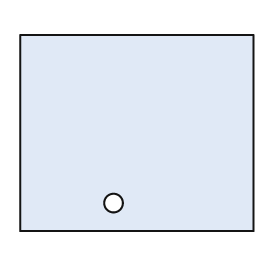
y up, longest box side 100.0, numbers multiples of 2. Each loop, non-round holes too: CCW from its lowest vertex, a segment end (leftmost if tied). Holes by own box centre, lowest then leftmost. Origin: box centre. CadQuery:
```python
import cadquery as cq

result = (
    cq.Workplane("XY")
    .moveTo(-50.0, -42.0)
    .lineTo(50.0, -42.0)
    .lineTo(50.0, 42.0)
    .lineTo(-50.0, 42.0)
    .close()
    .moveTo(-10.0, -30.0)
    .circle(4.0)
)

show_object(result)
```